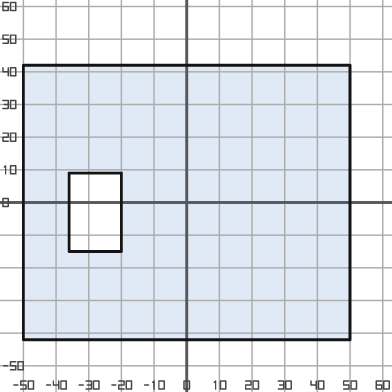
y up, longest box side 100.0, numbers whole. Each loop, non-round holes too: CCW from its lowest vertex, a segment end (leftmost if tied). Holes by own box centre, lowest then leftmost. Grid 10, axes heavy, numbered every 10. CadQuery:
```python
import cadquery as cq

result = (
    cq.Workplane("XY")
    .moveTo(-50.0, -42.0)
    .lineTo(50.0, -42.0)
    .lineTo(50.0, 42.0)
    .lineTo(-50.0, 42.0)
    .close()
    .moveTo(-36.0, -15.0)
    .lineTo(-20.0, -15.0)
    .lineTo(-20.0, 9.0)
    .lineTo(-36.0, 9.0)
    .close()
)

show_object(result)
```